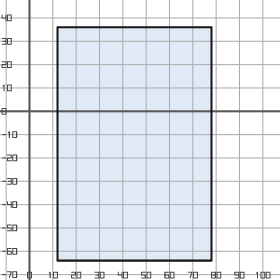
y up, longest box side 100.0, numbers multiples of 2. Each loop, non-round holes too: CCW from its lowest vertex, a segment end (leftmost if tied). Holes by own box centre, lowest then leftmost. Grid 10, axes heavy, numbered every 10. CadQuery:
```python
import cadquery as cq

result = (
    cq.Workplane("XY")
    .moveTo(12.0, -64.0)
    .lineTo(78.0, -64.0)
    .lineTo(78.0, 36.0)
    .lineTo(12.0, 36.0)
    .close()
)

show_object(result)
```